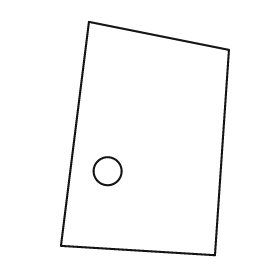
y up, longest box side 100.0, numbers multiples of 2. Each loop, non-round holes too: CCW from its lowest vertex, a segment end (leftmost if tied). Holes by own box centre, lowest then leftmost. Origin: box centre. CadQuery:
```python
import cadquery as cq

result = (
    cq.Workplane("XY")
    .moveTo(30.0, -50.0)
    .lineTo(36.0, 38.0)
    .lineTo(-24.0, 50.0)
    .lineTo(-36.0, -46.0)
    .close()
    .moveTo(-16.0, -14.0)
    .circle(6.0)
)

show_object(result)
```